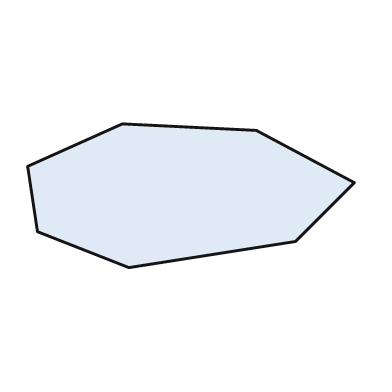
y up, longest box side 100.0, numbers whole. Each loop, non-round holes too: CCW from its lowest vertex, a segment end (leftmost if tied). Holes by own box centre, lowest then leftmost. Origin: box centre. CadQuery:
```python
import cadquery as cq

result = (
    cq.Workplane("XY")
    .moveTo(-19.0, -22.0)
    .lineTo(32.0, -14.0)
    .lineTo(50.0, 4.0)
    .lineTo(20.0, 20.0)
    .lineTo(-21.0, 22.0)
    .lineTo(-50.0, 9.0)
    .lineTo(-47.0, -11.0)
    .close()
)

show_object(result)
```